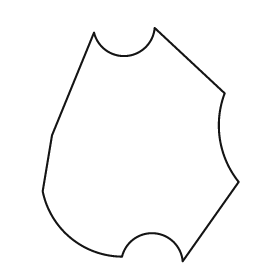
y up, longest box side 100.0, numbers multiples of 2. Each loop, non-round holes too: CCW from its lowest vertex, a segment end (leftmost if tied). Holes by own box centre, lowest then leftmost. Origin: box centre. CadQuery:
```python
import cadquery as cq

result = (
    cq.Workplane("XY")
    .moveTo(18.0, -50.0)
    .lineTo(42.0, -16.0)
    .threePointArc((34.0, 2.0), (36.0, 22.0))
    .lineTo(6.0, 50.0)
    .threePointArc((-6.0, 38.0), (-20.0, 48.0))
    .lineTo(-38.0, 4.0)
    .lineTo(-42.0, -20.0)
    .threePointArc((-30.0, -40.0), (-8.0, -48.0))
    .threePointArc((6.0, -38.0), (18.0, -50.0))
    .close()
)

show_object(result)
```